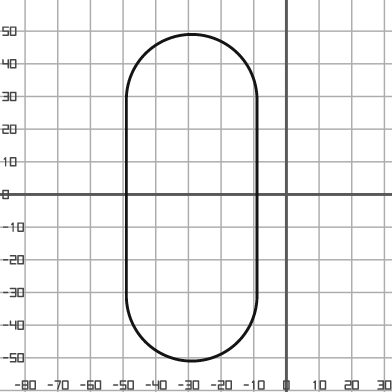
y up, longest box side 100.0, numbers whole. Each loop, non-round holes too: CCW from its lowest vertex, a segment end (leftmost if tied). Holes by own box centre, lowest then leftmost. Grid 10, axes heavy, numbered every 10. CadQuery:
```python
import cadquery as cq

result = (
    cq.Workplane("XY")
    .moveTo(-49.0, -31.0)
    .threePointArc((-29.0, -51.0), (-9.0, -31.0))
    .lineTo(-9.0, 29.0)
    .threePointArc((-29.0, 49.0), (-49.0, 29.0))
    .close()
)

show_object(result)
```